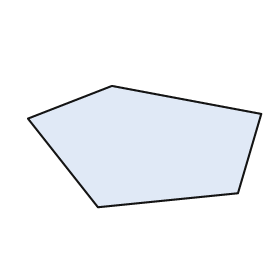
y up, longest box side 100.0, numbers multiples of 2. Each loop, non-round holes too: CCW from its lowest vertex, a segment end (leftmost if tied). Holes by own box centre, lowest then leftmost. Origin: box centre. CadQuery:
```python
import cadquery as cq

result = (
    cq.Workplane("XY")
    .moveTo(-20.0, -26.0)
    .lineTo(40.0, -20.0)
    .lineTo(50.0, 14.0)
    .lineTo(-14.0, 26.0)
    .lineTo(-50.0, 12.0)
    .close()
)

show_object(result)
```